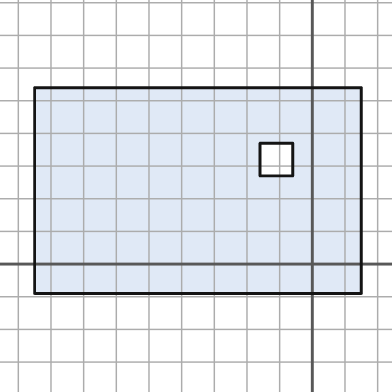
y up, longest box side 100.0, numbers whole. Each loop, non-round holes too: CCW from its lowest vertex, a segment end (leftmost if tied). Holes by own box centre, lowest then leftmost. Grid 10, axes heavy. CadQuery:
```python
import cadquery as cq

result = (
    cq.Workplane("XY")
    .moveTo(-85.0, -9.0)
    .lineTo(15.0, -9.0)
    .lineTo(15.0, 54.0)
    .lineTo(-85.0, 54.0)
    .close()
    .moveTo(-16.0, 27.0)
    .lineTo(-6.0, 27.0)
    .lineTo(-6.0, 37.0)
    .lineTo(-16.0, 37.0)
    .close()
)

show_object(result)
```